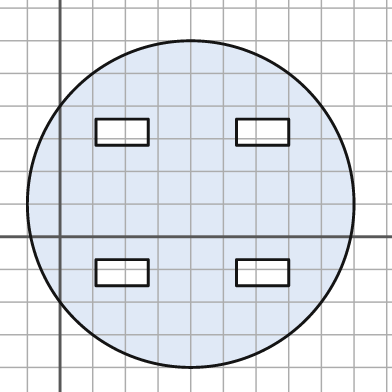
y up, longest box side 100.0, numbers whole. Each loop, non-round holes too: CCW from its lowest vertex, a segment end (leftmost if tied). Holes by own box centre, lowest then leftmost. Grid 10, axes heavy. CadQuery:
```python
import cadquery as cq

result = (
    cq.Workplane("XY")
    .moveTo(40.0, 10.0)
    .circle(50.0)
    .moveTo(11.0, -15.0)
    .lineTo(27.0, -15.0)
    .lineTo(27.0, -7.0)
    .lineTo(11.0, -7.0)
    .close()
    .moveTo(54.0, -15.0)
    .lineTo(70.0, -15.0)
    .lineTo(70.0, -7.0)
    .lineTo(54.0, -7.0)
    .close()
    .moveTo(11.0, 28.0)
    .lineTo(27.0, 28.0)
    .lineTo(27.0, 36.0)
    .lineTo(11.0, 36.0)
    .close()
    .moveTo(54.0, 28.0)
    .lineTo(70.0, 28.0)
    .lineTo(70.0, 36.0)
    .lineTo(54.0, 36.0)
    .close()
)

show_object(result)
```